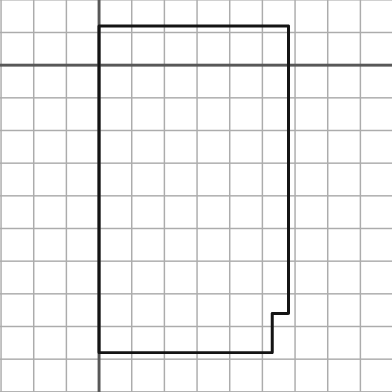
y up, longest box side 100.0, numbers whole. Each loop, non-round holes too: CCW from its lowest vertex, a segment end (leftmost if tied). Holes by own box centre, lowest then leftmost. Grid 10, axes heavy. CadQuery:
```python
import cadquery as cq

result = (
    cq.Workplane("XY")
    .moveTo(0.0, -88.0)
    .lineTo(53.0, -88.0)
    .lineTo(53.0, -76.0)
    .lineTo(58.0, -76.0)
    .lineTo(58.0, 12.0)
    .lineTo(0.0, 12.0)
    .close()
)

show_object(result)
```